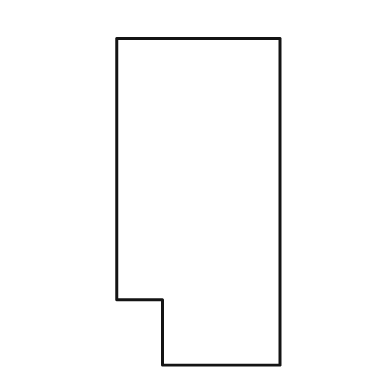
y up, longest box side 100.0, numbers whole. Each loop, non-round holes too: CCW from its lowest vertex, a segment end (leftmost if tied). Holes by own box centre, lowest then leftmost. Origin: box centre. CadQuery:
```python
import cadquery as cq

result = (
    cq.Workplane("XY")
    .moveTo(-11.0, -50.0)
    .lineTo(25.0, -50.0)
    .lineTo(25.0, 50.0)
    .lineTo(-25.0, 50.0)
    .lineTo(-25.0, -30.0)
    .lineTo(-11.0, -30.0)
    .close()
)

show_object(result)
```